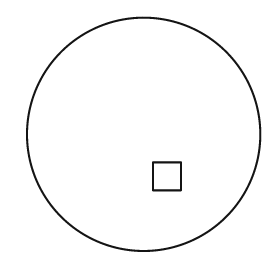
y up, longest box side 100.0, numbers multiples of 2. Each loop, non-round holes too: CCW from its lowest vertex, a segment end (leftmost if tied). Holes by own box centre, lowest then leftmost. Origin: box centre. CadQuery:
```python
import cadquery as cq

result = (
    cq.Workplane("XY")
    .moveTo(0.0, 0.0)
    .circle(50.0)
    .moveTo(4.0, -24.0)
    .lineTo(16.0, -24.0)
    .lineTo(16.0, -12.0)
    .lineTo(4.0, -12.0)
    .close()
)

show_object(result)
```